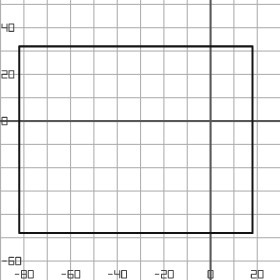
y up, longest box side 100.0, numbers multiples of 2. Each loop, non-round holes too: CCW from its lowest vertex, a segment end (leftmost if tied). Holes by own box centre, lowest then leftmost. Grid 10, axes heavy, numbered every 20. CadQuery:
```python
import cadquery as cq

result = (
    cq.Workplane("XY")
    .moveTo(-82.0, -48.0)
    .lineTo(18.0, -48.0)
    .lineTo(18.0, 32.0)
    .lineTo(-82.0, 32.0)
    .close()
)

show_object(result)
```